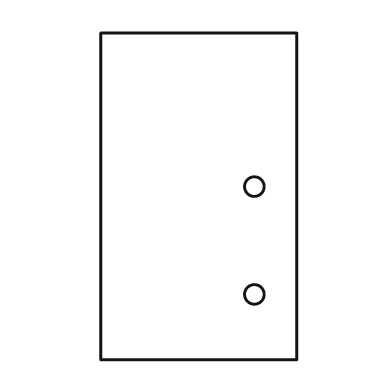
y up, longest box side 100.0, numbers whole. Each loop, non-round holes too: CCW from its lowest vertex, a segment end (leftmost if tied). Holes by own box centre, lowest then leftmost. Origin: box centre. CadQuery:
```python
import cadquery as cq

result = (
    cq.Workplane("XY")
    .moveTo(-30.0, -50.0)
    .lineTo(30.0, -50.0)
    .lineTo(30.0, 50.0)
    .lineTo(-30.0, 50.0)
    .close()
    .moveTo(17.0, -30.0)
    .circle(3.0)
    .moveTo(17.0, 3.0)
    .circle(3.0)
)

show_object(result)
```